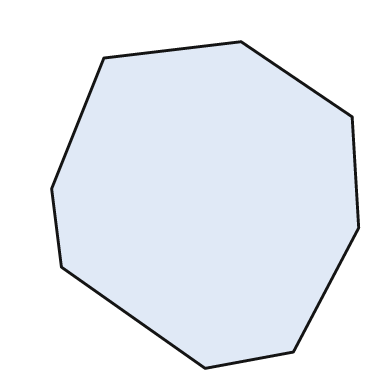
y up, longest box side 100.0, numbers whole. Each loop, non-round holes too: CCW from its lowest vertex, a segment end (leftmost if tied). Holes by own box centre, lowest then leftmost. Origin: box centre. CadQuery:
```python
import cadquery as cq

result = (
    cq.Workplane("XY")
    .moveTo(0.0, -50.0)
    .lineTo(27.0, -45.0)
    .lineTo(47.0, -7.0)
    .lineTo(45.0, 27.0)
    .lineTo(11.0, 50.0)
    .lineTo(-31.0, 45.0)
    .lineTo(-47.0, 5.0)
    .lineTo(-44.0, -19.0)
    .close()
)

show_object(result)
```